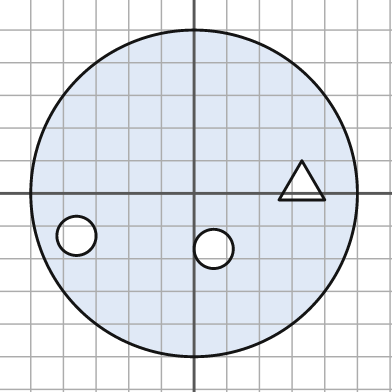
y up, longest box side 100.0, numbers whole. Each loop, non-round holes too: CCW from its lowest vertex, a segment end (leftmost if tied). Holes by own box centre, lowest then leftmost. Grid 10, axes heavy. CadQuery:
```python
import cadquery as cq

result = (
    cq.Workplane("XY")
    .moveTo(0.0, 0.0)
    .circle(50.0)
    .moveTo(6.0, -17.0)
    .circle(6.0)
    .moveTo(-36.0, -13.0)
    .circle(6.0)
    .moveTo(26.0, -2.0)
    .lineTo(40.0, -2.0)
    .lineTo(33.0, 10.0)
    .close()
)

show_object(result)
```